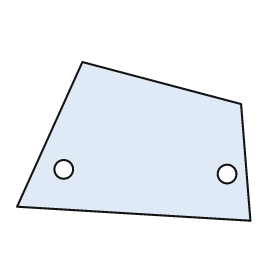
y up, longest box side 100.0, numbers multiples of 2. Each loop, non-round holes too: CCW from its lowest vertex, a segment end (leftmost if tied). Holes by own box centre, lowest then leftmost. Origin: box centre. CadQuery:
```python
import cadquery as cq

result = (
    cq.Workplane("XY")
    .moveTo(50.0, -34.0)
    .lineTo(46.0, 16.0)
    .lineTo(-22.0, 34.0)
    .lineTo(-50.0, -28.0)
    .close()
    .moveTo(40.0, -14.0)
    .circle(4.0)
    .moveTo(-30.0, -12.0)
    .circle(4.0)
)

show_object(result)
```